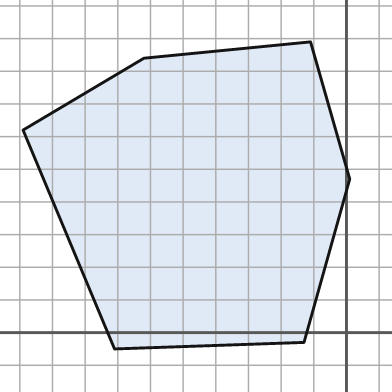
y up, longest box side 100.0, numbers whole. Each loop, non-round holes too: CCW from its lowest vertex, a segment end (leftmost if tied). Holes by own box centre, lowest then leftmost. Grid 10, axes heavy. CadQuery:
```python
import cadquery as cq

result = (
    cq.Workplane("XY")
    .moveTo(-71.0, -5.0)
    .lineTo(-13.0, -3.0)
    .lineTo(1.0, 47.0)
    .lineTo(-11.0, 89.0)
    .lineTo(-62.0, 84.0)
    .lineTo(-99.0, 62.0)
    .close()
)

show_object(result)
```